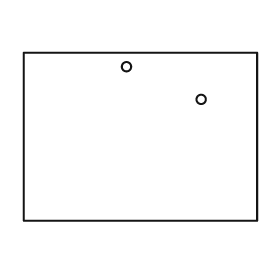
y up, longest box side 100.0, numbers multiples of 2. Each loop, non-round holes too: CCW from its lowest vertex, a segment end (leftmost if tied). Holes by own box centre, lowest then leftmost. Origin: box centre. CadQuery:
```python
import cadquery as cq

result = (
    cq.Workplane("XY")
    .moveTo(-50.0, -36.0)
    .lineTo(50.0, -36.0)
    .lineTo(50.0, 36.0)
    .lineTo(-50.0, 36.0)
    .close()
    .moveTo(26.0, 16.0)
    .circle(2.0)
    .moveTo(-6.0, 30.0)
    .circle(2.0)
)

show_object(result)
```